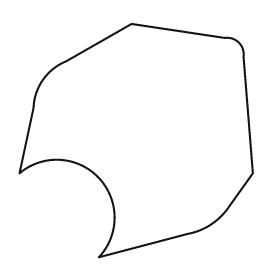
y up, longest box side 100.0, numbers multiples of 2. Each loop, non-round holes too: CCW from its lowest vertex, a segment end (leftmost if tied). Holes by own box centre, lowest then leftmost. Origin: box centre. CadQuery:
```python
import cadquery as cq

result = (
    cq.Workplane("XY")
    .moveTo(-16.0, -50.0)
    .lineTo(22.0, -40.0)
    .threePointArc((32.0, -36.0), (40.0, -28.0))
    .lineTo(50.0, -14.0)
    .lineTo(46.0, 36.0)
    .threePointArc((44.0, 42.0), (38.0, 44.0))
    .lineTo(-2.0, 50.0)
    .lineTo(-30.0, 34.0)
    .threePointArc((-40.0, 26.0), (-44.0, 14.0))
    .lineTo(-50.0, -14.0)
    .threePointArc((-16.0, -16.0), (-16.0, -50.0))
    .close()
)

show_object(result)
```